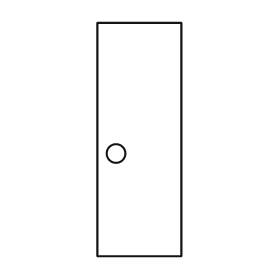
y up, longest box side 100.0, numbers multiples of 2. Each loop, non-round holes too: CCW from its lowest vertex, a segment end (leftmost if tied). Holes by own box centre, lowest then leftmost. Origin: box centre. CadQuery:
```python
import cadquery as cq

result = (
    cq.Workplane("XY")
    .moveTo(-18.0, -50.0)
    .lineTo(18.0, -50.0)
    .lineTo(18.0, 50.0)
    .lineTo(-18.0, 50.0)
    .close()
    .moveTo(-10.0, -6.0)
    .circle(4.0)
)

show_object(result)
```